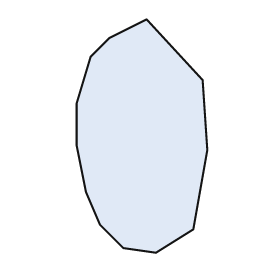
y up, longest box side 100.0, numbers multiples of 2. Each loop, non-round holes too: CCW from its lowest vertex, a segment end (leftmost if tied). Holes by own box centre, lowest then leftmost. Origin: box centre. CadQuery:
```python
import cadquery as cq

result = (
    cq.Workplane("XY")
    .moveTo(6.0, -50.0)
    .lineTo(22.0, -40.0)
    .lineTo(28.0, -6.0)
    .lineTo(26.0, 24.0)
    .lineTo(2.0, 50.0)
    .lineTo(-14.0, 42.0)
    .lineTo(-22.0, 34.0)
    .lineTo(-28.0, 14.0)
    .lineTo(-28.0, -4.0)
    .lineTo(-24.0, -24.0)
    .lineTo(-18.0, -38.0)
    .lineTo(-8.0, -48.0)
    .close()
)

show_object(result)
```